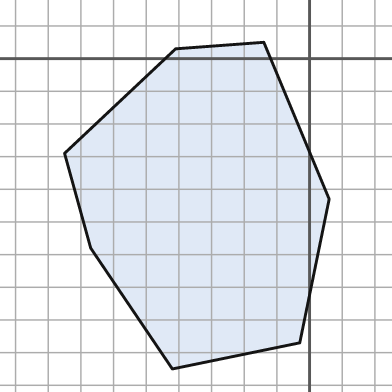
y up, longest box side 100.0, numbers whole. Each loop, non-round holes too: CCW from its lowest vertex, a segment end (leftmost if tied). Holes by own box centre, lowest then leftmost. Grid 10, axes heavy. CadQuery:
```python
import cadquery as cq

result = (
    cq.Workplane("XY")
    .moveTo(-42.0, -95.0)
    .lineTo(-3.0, -87.0)
    .lineTo(6.0, -43.0)
    .lineTo(-14.0, 5.0)
    .lineTo(-41.0, 3.0)
    .lineTo(-75.0, -29.0)
    .lineTo(-67.0, -58.0)
    .close()
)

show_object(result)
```